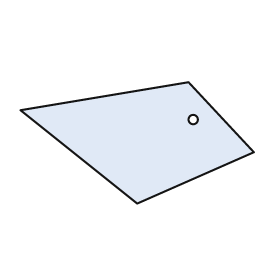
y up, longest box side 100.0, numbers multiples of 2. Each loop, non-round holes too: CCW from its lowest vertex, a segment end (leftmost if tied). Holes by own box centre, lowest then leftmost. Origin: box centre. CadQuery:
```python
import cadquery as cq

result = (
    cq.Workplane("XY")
    .moveTo(0.0, -26.0)
    .lineTo(50.0, -4.0)
    .lineTo(22.0, 26.0)
    .lineTo(-50.0, 14.0)
    .close()
    .moveTo(24.0, 10.0)
    .circle(2.0)
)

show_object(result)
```